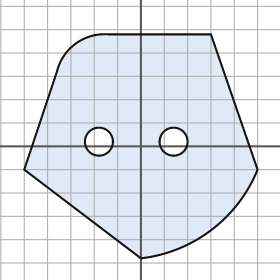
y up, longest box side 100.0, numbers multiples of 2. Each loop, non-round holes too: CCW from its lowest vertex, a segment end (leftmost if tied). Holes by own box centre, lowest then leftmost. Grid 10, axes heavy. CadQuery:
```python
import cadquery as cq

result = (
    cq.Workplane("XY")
    .moveTo(0.0, -48.0)
    .threePointArc((30.0, -36.0), (50.0, -10.0))
    .lineTo(30.0, 48.0)
    .lineTo(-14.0, 48.0)
    .threePointArc((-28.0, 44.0), (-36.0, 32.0))
    .lineTo(-50.0, -10.0)
    .close()
    .moveTo(-18.0, 2.0)
    .circle(6.0)
    .moveTo(14.0, 2.0)
    .circle(6.0)
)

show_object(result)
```